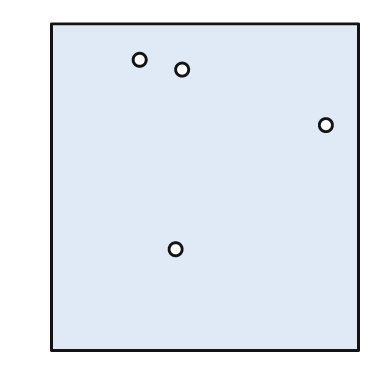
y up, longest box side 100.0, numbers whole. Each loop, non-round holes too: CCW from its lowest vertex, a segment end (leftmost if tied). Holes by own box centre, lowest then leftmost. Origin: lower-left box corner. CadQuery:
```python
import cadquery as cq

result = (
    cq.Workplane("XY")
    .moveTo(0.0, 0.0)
    .lineTo(94.0, 0.0)
    .lineTo(94.0, 100.0)
    .lineTo(0.0, 100.0)
    .close()
    .moveTo(38.0, 31.0)
    .circle(2.0)
    .moveTo(84.0, 69.0)
    .circle(2.0)
    .moveTo(40.0, 86.0)
    .circle(2.0)
    .moveTo(27.0, 89.0)
    .circle(2.0)
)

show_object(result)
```